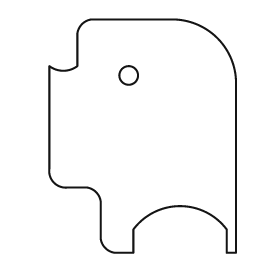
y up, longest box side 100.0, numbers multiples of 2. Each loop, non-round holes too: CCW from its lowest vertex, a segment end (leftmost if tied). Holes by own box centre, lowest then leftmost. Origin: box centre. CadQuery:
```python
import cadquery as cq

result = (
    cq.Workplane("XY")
    .moveTo(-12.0, -50.0)
    .lineTo(-4.0, -50.0)
    .lineTo(-4.0, -40.0)
    .threePointArc((16.0, -30.0), (36.0, -40.0))
    .lineTo(36.0, -50.0)
    .lineTo(40.0, -50.0)
    .lineTo(40.0, 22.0)
    .threePointArc((32.0, 42.0), (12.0, 50.0))
    .lineTo(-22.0, 50.0)
    .threePointArc((-26.0, 48.0), (-28.0, 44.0))
    .lineTo(-28.0, 30.0)
    .threePointArc((-34.0, 28.0), (-40.0, 30.0))
    .lineTo(-40.0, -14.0)
    .threePointArc((-38.0, -20.0), (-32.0, -22.0))
    .lineTo(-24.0, -22.0)
    .threePointArc((-20.0, -24.0), (-18.0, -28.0))
    .lineTo(-18.0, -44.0)
    .threePointArc((-16.0, -48.0), (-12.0, -50.0))
    .close()
    .moveTo(-6.0, 26.0)
    .circle(4.0)
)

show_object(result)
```